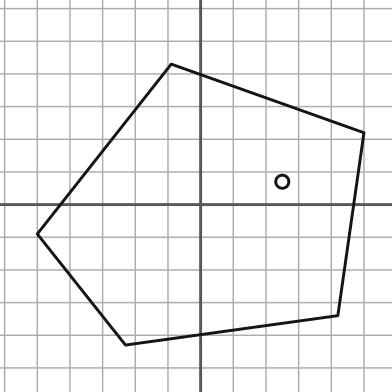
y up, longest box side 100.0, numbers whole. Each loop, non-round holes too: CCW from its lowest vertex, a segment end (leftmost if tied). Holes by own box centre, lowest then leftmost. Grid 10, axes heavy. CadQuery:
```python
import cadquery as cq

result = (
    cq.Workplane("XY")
    .moveTo(-23.0, -43.0)
    .lineTo(42.0, -34.0)
    .lineTo(50.0, 22.0)
    .lineTo(-9.0, 43.0)
    .lineTo(-50.0, -9.0)
    .close()
    .moveTo(25.0, 7.0)
    .circle(2.0)
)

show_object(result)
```